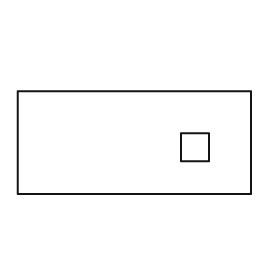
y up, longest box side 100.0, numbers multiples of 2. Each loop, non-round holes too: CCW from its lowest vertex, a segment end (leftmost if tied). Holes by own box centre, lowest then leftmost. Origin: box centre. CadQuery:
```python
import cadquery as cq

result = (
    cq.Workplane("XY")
    .moveTo(-50.0, -22.0)
    .lineTo(50.0, -22.0)
    .lineTo(50.0, 22.0)
    .lineTo(-50.0, 22.0)
    .close()
    .moveTo(20.0, -8.0)
    .lineTo(32.0, -8.0)
    .lineTo(32.0, 4.0)
    .lineTo(20.0, 4.0)
    .close()
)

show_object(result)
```